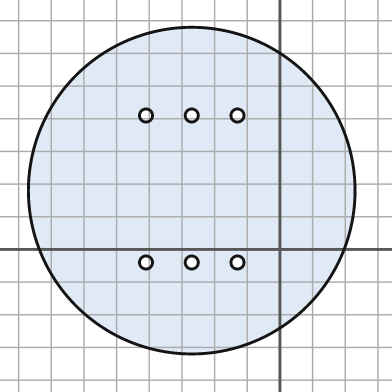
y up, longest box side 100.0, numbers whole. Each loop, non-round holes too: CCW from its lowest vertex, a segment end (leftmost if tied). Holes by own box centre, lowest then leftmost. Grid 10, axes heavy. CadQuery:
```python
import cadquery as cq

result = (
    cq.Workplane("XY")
    .moveTo(-27.0, 18.0)
    .circle(50.0)
    .moveTo(-41.0, -4.0)
    .circle(2.0)
    .moveTo(-27.0, -4.0)
    .circle(2.0)
    .moveTo(-13.0, -4.0)
    .circle(2.0)
    .moveTo(-41.0, 41.0)
    .circle(2.0)
    .moveTo(-27.0, 41.0)
    .circle(2.0)
    .moveTo(-13.0, 41.0)
    .circle(2.0)
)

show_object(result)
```